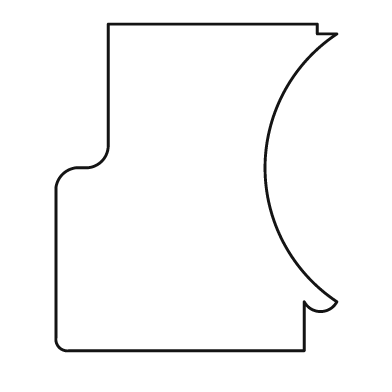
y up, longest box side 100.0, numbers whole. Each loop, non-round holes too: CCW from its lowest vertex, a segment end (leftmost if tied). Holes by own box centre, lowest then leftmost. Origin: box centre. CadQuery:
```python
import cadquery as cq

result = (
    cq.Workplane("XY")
    .moveTo(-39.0, -50.0)
    .lineTo(33.0, -50.0)
    .lineTo(33.0, -35.0)
    .threePointArc((38.0, -38.0), (43.0, -35.0))
    .threePointArc((21.0, 6.0), (43.0, 47.0))
    .lineTo(37.0, 47.0)
    .lineTo(37.0, 50.0)
    .lineTo(-27.0, 50.0)
    .lineTo(-27.0, 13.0)
    .threePointArc((-29.0, 8.0), (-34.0, 6.0))
    .lineTo(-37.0, 6.0)
    .threePointArc((-41.0, 4.0), (-43.0, 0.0))
    .lineTo(-43.0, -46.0)
    .threePointArc((-42.0, -49.0), (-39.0, -50.0))
    .close()
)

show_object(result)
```